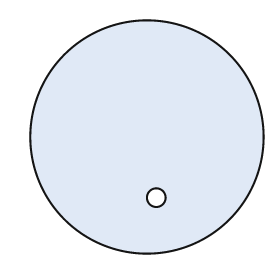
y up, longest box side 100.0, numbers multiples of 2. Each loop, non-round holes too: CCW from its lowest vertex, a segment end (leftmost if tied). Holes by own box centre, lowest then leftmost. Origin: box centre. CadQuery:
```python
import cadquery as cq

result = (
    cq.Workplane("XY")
    .moveTo(0.0, 0.0)
    .circle(50.0)
    .moveTo(4.0, -26.0)
    .circle(4.0)
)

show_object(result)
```